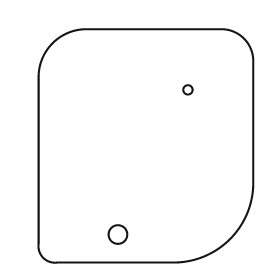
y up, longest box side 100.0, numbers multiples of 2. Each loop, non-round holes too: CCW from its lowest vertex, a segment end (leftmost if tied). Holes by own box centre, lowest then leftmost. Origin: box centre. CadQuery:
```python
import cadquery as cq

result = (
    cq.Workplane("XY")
    .moveTo(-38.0, -50.0)
    .lineTo(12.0, -50.0)
    .threePointArc((36.0, -40.0), (46.0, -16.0))
    .lineTo(46.0, 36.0)
    .threePointArc((42.0, 46.0), (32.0, 50.0))
    .lineTo(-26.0, 50.0)
    .threePointArc((-40.0, 44.0), (-46.0, 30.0))
    .lineTo(-46.0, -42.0)
    .threePointArc((-44.0, -48.0), (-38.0, -50.0))
    .close()
    .moveTo(-12.0, -38.0)
    .circle(4.0)
    .moveTo(18.0, 24.0)
    .circle(2.0)
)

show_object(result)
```